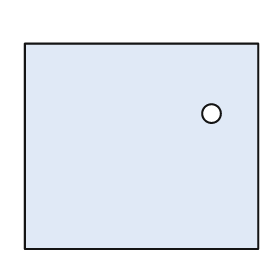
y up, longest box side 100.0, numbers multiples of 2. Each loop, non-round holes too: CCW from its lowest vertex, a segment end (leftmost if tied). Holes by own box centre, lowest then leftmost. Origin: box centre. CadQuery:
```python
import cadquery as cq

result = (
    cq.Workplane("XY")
    .moveTo(-50.0, -44.0)
    .lineTo(50.0, -44.0)
    .lineTo(50.0, 44.0)
    .lineTo(-50.0, 44.0)
    .close()
    .moveTo(30.0, 14.0)
    .circle(4.0)
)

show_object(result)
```